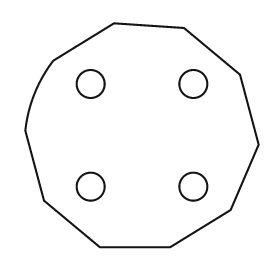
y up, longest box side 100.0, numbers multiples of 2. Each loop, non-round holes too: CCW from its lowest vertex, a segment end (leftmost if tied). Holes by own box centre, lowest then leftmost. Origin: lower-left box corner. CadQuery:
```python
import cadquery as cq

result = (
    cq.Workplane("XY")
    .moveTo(32.0, 0.0)
    .lineTo(62.0, 0.0)
    .lineTo(88.0, 16.0)
    .lineTo(100.0, 44.0)
    .lineTo(92.0, 74.0)
    .lineTo(68.0, 94.0)
    .lineTo(38.0, 96.0)
    .lineTo(12.0, 80.0)
    .threePointArc((4.0, 66.0), (0.0, 50.0))
    .lineTo(8.0, 20.0)
    .close()
    .moveTo(28.0, 26.0)
    .circle(6.0)
    .moveTo(72.0, 26.0)
    .circle(6.0)
    .moveTo(28.0, 70.0)
    .circle(6.0)
    .moveTo(72.0, 70.0)
    .circle(6.0)
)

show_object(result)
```